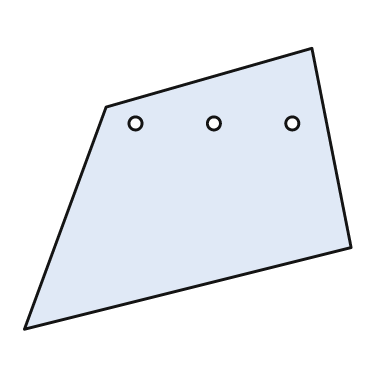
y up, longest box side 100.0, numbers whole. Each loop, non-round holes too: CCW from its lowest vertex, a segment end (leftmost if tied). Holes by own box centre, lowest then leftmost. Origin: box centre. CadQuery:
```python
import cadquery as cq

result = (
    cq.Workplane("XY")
    .moveTo(-50.0, -43.0)
    .lineTo(50.0, -18.0)
    .lineTo(38.0, 43.0)
    .lineTo(-25.0, 25.0)
    .close()
    .moveTo(-16.0, 20.0)
    .circle(2.0)
    .moveTo(8.0, 20.0)
    .circle(2.0)
    .moveTo(32.0, 20.0)
    .circle(2.0)
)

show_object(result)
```